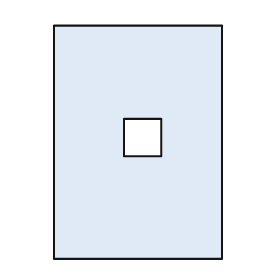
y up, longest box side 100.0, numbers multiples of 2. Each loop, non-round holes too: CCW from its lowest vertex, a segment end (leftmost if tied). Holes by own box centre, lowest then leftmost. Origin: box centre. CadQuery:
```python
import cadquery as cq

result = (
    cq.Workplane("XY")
    .moveTo(-36.0, -50.0)
    .lineTo(36.0, -50.0)
    .lineTo(36.0, 50.0)
    .lineTo(-36.0, 50.0)
    .close()
    .moveTo(-6.0, -6.0)
    .lineTo(10.0, -6.0)
    .lineTo(10.0, 10.0)
    .lineTo(-6.0, 10.0)
    .close()
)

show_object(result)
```